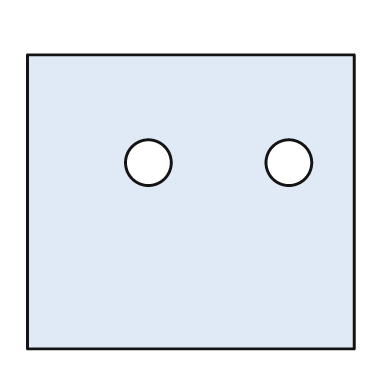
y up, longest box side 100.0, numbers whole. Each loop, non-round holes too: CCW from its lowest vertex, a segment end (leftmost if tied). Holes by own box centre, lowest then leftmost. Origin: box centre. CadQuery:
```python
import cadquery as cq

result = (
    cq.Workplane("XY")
    .moveTo(-50.0, -45.0)
    .lineTo(50.0, -45.0)
    .lineTo(50.0, 45.0)
    .lineTo(-50.0, 45.0)
    .close()
    .moveTo(-13.0, 12.0)
    .circle(7.0)
    .moveTo(30.0, 12.0)
    .circle(7.0)
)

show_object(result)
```